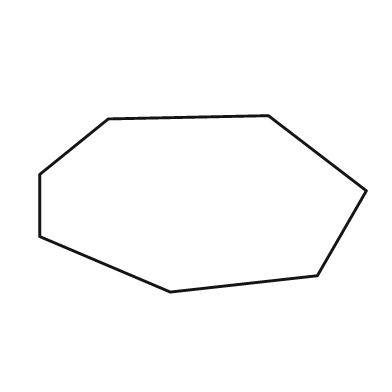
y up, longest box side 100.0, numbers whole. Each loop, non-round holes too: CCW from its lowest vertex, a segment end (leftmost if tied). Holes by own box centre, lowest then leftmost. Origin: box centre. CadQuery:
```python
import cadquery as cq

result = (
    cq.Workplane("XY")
    .moveTo(-10.0, -27.0)
    .lineTo(35.0, -22.0)
    .lineTo(50.0, 4.0)
    .lineTo(20.0, 27.0)
    .lineTo(-29.0, 26.0)
    .lineTo(-50.0, 9.0)
    .lineTo(-50.0, -10.0)
    .close()
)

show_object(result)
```